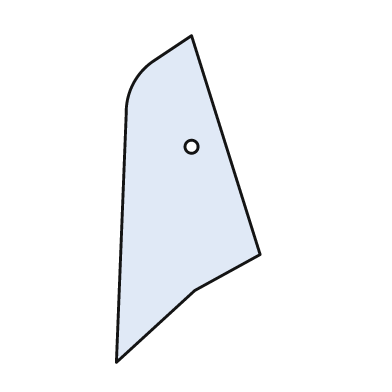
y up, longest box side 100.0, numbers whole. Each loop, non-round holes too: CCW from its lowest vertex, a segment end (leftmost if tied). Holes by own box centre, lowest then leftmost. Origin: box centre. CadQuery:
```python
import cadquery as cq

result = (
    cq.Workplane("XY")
    .moveTo(-22.0, -50.0)
    .lineTo(2.0, -28.0)
    .lineTo(22.0, -17.0)
    .lineTo(1.0, 50.0)
    .lineTo(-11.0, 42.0)
    .threePointArc((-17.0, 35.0), (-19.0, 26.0))
    .close()
    .moveTo(1.0, 16.0)
    .circle(2.0)
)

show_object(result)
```